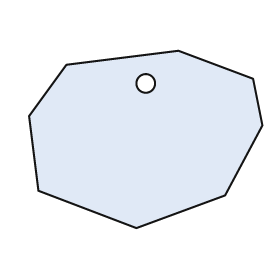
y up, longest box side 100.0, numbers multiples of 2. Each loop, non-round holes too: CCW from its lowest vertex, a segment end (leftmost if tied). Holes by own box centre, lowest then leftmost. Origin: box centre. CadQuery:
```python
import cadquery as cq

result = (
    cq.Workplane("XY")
    .moveTo(-4.0, -38.0)
    .lineTo(34.0, -24.0)
    .lineTo(50.0, 6.0)
    .lineTo(46.0, 26.0)
    .lineTo(14.0, 38.0)
    .lineTo(-34.0, 32.0)
    .lineTo(-50.0, 10.0)
    .lineTo(-46.0, -22.0)
    .close()
    .moveTo(0.0, 24.0)
    .circle(4.0)
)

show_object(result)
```